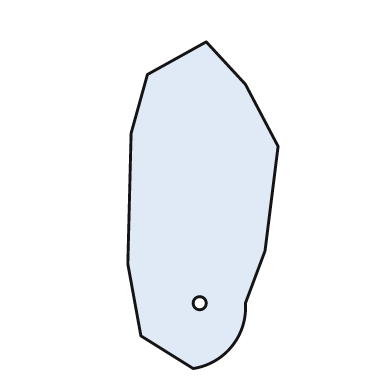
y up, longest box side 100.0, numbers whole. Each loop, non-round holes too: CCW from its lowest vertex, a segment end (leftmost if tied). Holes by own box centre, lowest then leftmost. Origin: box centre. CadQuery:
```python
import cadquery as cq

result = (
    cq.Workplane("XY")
    .moveTo(-3.0, -50.0)
    .threePointArc((9.0, -43.0), (13.0, -30.0))
    .lineTo(19.0, -14.0)
    .lineTo(23.0, 18.0)
    .lineTo(13.0, 37.0)
    .lineTo(1.0, 50.0)
    .lineTo(-17.0, 40.0)
    .lineTo(-22.0, 22.0)
    .lineTo(-23.0, -18.0)
    .lineTo(-19.0, -40.0)
    .close()
    .moveTo(-1.0, -30.0)
    .circle(2.0)
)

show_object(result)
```